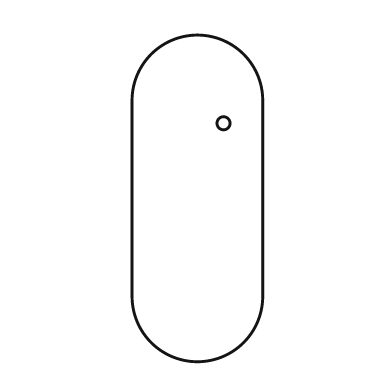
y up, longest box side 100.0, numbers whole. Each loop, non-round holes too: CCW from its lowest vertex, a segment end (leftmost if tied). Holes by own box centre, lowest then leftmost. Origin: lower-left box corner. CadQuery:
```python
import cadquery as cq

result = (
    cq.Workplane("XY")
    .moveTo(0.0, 20.0)
    .threePointArc((20.0, 0.0), (40.0, 20.0))
    .lineTo(40.0, 80.0)
    .threePointArc((20.0, 100.0), (0.0, 80.0))
    .close()
    .moveTo(28.0, 73.0)
    .circle(2.0)
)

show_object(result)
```